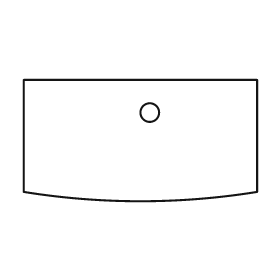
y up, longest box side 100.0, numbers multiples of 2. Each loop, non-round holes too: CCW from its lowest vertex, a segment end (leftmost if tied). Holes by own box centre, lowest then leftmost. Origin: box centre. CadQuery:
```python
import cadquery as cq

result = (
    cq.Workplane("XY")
    .moveTo(-50.0, -22.0)
    .threePointArc((0.0, -26.0), (50.0, -22.0))
    .lineTo(50.0, 26.0)
    .lineTo(-50.0, 26.0)
    .close()
    .moveTo(4.0, 12.0)
    .circle(4.0)
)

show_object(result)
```